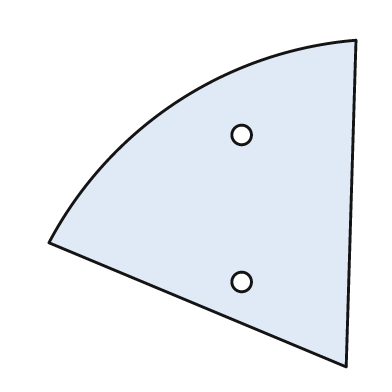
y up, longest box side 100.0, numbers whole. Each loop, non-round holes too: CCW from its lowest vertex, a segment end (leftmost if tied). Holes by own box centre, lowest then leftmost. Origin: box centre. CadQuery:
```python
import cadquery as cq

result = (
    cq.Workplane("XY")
    .moveTo(44.0, -50.0)
    .lineTo(47.0, 50.0)
    .threePointArc((-8.0, 31.0), (-47.0, -12.0))
    .close()
    .moveTo(12.0, -24.0)
    .circle(3.0)
    .moveTo(12.0, 21.0)
    .circle(3.0)
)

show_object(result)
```